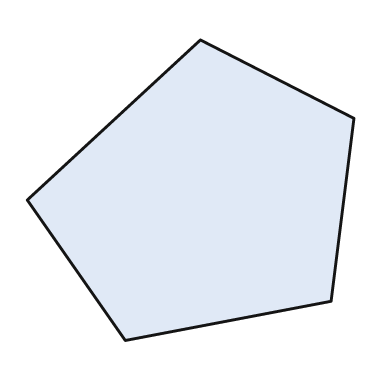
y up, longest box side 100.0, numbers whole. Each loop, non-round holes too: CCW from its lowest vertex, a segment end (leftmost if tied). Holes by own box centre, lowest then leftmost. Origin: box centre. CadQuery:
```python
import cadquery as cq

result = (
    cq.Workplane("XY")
    .moveTo(-20.0, -46.0)
    .lineTo(43.0, -34.0)
    .lineTo(50.0, 22.0)
    .lineTo(3.0, 46.0)
    .lineTo(-50.0, -3.0)
    .close()
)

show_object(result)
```